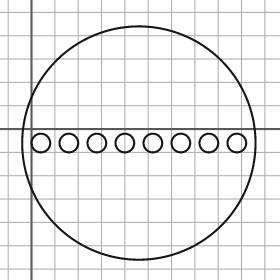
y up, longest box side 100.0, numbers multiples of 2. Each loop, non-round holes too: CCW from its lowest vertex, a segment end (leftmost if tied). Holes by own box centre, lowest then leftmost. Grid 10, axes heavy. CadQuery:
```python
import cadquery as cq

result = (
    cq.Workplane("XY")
    .moveTo(46.0, -6.0)
    .circle(50.0)
    .moveTo(4.0, -6.0)
    .circle(4.0)
    .moveTo(16.0, -6.0)
    .circle(4.0)
    .moveTo(28.0, -6.0)
    .circle(4.0)
    .moveTo(40.0, -6.0)
    .circle(4.0)
    .moveTo(52.0, -6.0)
    .circle(4.0)
    .moveTo(64.0, -6.0)
    .circle(4.0)
    .moveTo(76.0, -6.0)
    .circle(4.0)
    .moveTo(88.0, -6.0)
    .circle(4.0)
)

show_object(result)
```